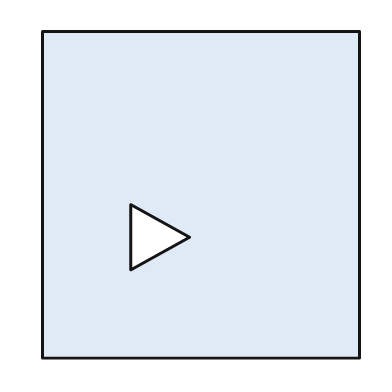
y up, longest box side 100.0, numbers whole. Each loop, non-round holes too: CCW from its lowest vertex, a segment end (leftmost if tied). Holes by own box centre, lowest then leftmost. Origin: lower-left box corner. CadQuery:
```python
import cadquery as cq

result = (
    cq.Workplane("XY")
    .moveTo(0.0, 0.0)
    .lineTo(97.0, 0.0)
    .lineTo(97.0, 100.0)
    .lineTo(0.0, 100.0)
    .close()
    .moveTo(27.0, 27.0)
    .lineTo(45.0, 37.0)
    .lineTo(27.0, 47.0)
    .close()
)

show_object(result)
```